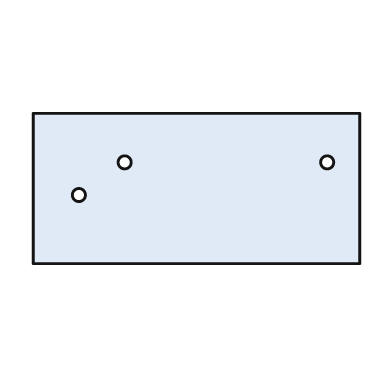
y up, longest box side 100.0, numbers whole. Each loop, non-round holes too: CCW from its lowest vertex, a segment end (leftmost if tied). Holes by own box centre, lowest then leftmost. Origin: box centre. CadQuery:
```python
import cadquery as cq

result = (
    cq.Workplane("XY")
    .moveTo(-50.0, -23.0)
    .lineTo(50.0, -23.0)
    .lineTo(50.0, 23.0)
    .lineTo(-50.0, 23.0)
    .close()
    .moveTo(-36.0, -2.0)
    .circle(2.0)
    .moveTo(-22.0, 8.0)
    .circle(2.0)
    .moveTo(40.0, 8.0)
    .circle(2.0)
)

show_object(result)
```